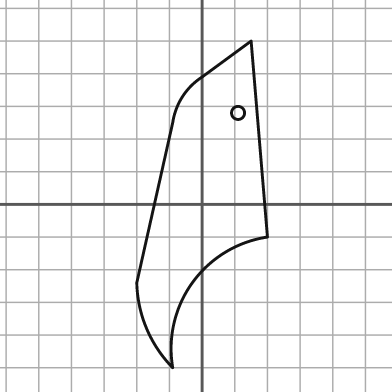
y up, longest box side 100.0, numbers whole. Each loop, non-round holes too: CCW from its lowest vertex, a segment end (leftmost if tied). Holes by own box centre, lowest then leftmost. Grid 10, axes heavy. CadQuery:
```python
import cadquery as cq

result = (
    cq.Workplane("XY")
    .moveTo(-9.0, -50.0)
    .threePointArc((-3.0, -24.0), (20.0, -10.0))
    .lineTo(15.0, 50.0)
    .lineTo(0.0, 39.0)
    .threePointArc((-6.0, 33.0), (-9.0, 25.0))
    .lineTo(-20.0, -24.0)
    .threePointArc((-17.0, -38.0), (-9.0, -50.0))
    .close()
    .moveTo(11.0, 28.0)
    .circle(2.0)
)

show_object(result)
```